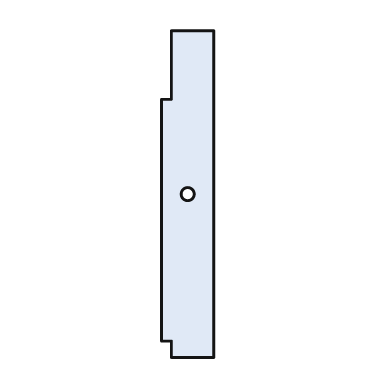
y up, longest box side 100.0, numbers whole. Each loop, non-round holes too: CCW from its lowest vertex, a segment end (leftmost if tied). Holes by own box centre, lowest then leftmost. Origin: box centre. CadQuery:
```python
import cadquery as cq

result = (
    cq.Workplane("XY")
    .moveTo(-5.0, -50.0)
    .lineTo(8.0, -50.0)
    .lineTo(8.0, 50.0)
    .lineTo(-5.0, 50.0)
    .lineTo(-5.0, 29.0)
    .lineTo(-8.0, 29.0)
    .lineTo(-8.0, -45.0)
    .lineTo(-5.0, -45.0)
    .close()
    .moveTo(0.0, 0.0)
    .circle(2.0)
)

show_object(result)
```